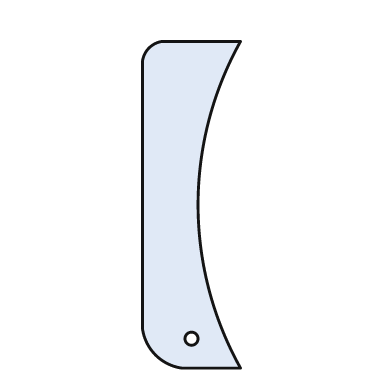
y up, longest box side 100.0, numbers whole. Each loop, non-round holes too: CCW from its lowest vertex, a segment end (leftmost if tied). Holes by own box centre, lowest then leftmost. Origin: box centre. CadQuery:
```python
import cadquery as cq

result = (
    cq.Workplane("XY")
    .moveTo(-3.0, -50.0)
    .lineTo(15.0, -50.0)
    .threePointArc((2.0, 0.0), (15.0, 50.0))
    .lineTo(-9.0, 50.0)
    .threePointArc((-13.0, 48.0), (-15.0, 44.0))
    .lineTo(-15.0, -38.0)
    .threePointArc((-11.0, -46.0), (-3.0, -50.0))
    .close()
    .moveTo(0.0, -41.0)
    .circle(2.0)
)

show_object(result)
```